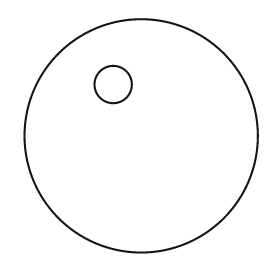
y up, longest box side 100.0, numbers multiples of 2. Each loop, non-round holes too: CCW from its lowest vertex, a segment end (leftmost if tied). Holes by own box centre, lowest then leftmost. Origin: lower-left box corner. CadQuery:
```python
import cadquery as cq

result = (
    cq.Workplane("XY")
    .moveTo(50.0, 50.0)
    .circle(50.0)
    .moveTo(38.0, 72.0)
    .circle(8.0)
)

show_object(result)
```